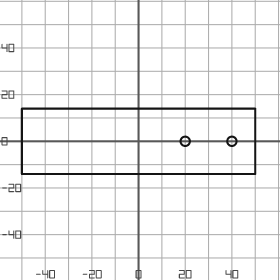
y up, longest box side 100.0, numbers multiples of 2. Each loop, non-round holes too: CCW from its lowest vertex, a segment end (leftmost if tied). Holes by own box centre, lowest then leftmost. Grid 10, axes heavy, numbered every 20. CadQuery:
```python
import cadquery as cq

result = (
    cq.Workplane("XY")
    .moveTo(-50.0, -14.0)
    .lineTo(50.0, -14.0)
    .lineTo(50.0, 14.0)
    .lineTo(-50.0, 14.0)
    .close()
    .moveTo(20.0, 0.0)
    .circle(2.0)
    .moveTo(40.0, 0.0)
    .circle(2.0)
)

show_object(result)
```